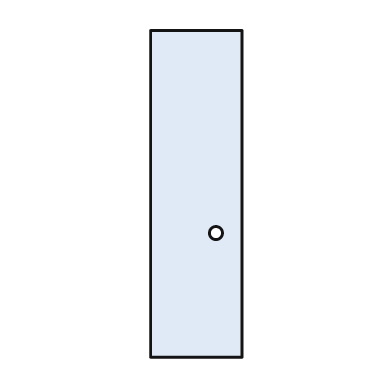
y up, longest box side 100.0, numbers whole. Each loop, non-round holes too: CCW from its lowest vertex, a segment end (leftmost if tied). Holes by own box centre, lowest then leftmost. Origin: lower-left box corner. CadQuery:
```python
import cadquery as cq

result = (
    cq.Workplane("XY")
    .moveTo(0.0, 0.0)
    .lineTo(28.0, 0.0)
    .lineTo(28.0, 100.0)
    .lineTo(0.0, 100.0)
    .close()
    .moveTo(20.0, 38.0)
    .circle(2.0)
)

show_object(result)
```